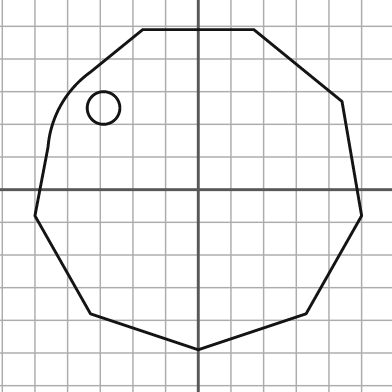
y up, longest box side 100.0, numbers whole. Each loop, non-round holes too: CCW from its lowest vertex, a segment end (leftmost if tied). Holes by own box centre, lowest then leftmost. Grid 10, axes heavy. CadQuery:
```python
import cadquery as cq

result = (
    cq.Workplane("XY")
    .moveTo(0.0, -49.0)
    .lineTo(33.0, -38.0)
    .lineTo(50.0, -8.0)
    .lineTo(44.0, 27.0)
    .lineTo(17.0, 49.0)
    .lineTo(-17.0, 49.0)
    .lineTo(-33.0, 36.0)
    .threePointArc((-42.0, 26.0), (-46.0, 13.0))
    .lineTo(-50.0, -8.0)
    .lineTo(-33.0, -38.0)
    .close()
    .moveTo(-29.0, 25.0)
    .circle(5.0)
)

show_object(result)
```